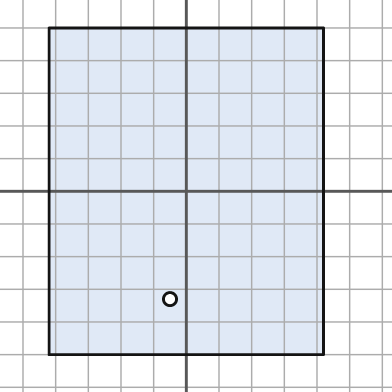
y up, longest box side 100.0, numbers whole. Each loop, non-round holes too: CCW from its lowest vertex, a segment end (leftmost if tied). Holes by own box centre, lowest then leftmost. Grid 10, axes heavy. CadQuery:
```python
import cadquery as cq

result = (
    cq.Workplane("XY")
    .moveTo(-42.0, -50.0)
    .lineTo(42.0, -50.0)
    .lineTo(42.0, 50.0)
    .lineTo(-42.0, 50.0)
    .close()
    .moveTo(-5.0, -33.0)
    .circle(2.0)
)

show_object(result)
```